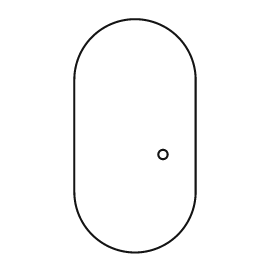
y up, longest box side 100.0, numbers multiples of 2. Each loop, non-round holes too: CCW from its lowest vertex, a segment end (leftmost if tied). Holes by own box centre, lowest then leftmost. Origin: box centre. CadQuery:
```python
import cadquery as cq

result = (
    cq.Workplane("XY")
    .moveTo(-26.0, -24.0)
    .threePointArc((0.0, -50.0), (26.0, -24.0))
    .lineTo(26.0, 24.0)
    .threePointArc((0.0, 50.0), (-26.0, 24.0))
    .close()
    .moveTo(12.0, -8.0)
    .circle(2.0)
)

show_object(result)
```